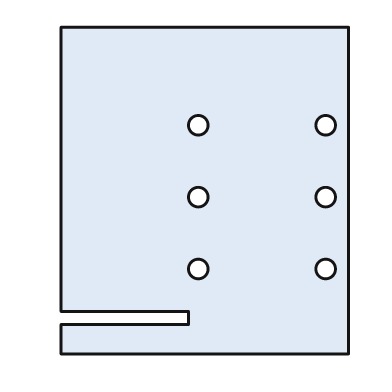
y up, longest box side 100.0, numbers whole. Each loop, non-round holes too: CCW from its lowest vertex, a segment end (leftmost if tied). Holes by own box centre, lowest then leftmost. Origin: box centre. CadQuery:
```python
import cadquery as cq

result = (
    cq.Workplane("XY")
    .moveTo(-44.0, -50.0)
    .lineTo(44.0, -50.0)
    .lineTo(44.0, 50.0)
    .lineTo(-44.0, 50.0)
    .lineTo(-44.0, -37.0)
    .lineTo(-5.0, -37.0)
    .lineTo(-5.0, -41.0)
    .lineTo(-44.0, -41.0)
    .close()
    .moveTo(-2.0, -24.0)
    .circle(3.0)
    .moveTo(37.0, -24.0)
    .circle(3.0)
    .moveTo(-2.0, -2.0)
    .circle(3.0)
    .moveTo(37.0, -2.0)
    .circle(3.0)
    .moveTo(-2.0, 20.0)
    .circle(3.0)
    .moveTo(37.0, 20.0)
    .circle(3.0)
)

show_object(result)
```